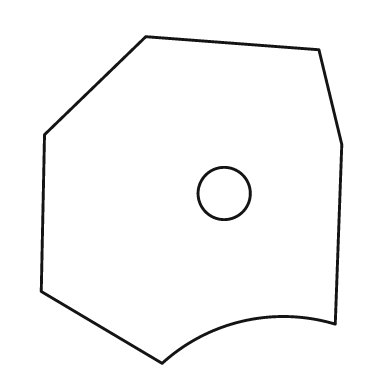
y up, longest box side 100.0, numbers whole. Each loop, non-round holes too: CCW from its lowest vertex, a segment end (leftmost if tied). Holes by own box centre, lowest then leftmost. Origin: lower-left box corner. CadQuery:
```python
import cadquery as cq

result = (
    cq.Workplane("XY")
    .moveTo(37.0, 0.0)
    .threePointArc((62.0, 13.0), (90.0, 12.0))
    .lineTo(92.0, 67.0)
    .lineTo(85.0, 96.0)
    .lineTo(32.0, 100.0)
    .lineTo(1.0, 70.0)
    .lineTo(0.0, 22.0)
    .close()
    .moveTo(56.0, 52.0)
    .circle(8.0)
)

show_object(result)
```